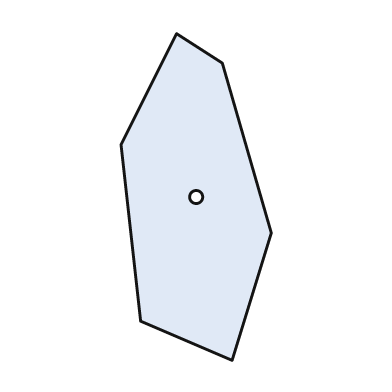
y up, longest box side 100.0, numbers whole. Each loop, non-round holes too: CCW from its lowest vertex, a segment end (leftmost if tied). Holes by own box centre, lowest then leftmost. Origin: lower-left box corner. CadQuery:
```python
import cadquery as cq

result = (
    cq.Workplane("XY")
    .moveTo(34.0, 0.0)
    .lineTo(46.0, 39.0)
    .lineTo(31.0, 91.0)
    .lineTo(17.0, 100.0)
    .lineTo(0.0, 66.0)
    .lineTo(6.0, 12.0)
    .close()
    .moveTo(23.0, 50.0)
    .circle(2.0)
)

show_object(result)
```